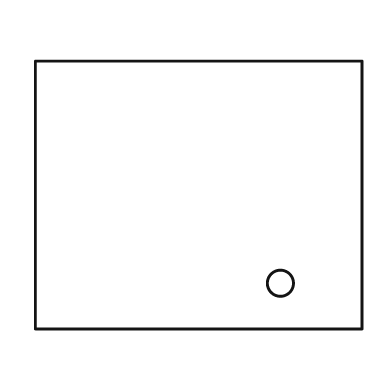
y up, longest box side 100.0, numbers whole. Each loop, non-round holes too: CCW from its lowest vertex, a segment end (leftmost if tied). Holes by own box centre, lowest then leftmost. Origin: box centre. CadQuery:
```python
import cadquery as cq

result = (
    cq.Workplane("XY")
    .moveTo(-50.0, -41.0)
    .lineTo(50.0, -41.0)
    .lineTo(50.0, 41.0)
    .lineTo(-50.0, 41.0)
    .close()
    .moveTo(25.0, -27.0)
    .circle(4.0)
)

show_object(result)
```